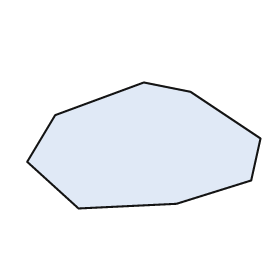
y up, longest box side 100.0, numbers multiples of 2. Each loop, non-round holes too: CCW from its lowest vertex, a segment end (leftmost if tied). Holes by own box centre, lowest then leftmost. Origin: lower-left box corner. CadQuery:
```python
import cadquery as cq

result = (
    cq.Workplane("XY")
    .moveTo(22.0, 0.0)
    .lineTo(64.0, 2.0)
    .lineTo(96.0, 12.0)
    .lineTo(100.0, 30.0)
    .lineTo(70.0, 50.0)
    .lineTo(50.0, 54.0)
    .lineTo(12.0, 40.0)
    .lineTo(0.0, 20.0)
    .close()
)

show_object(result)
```